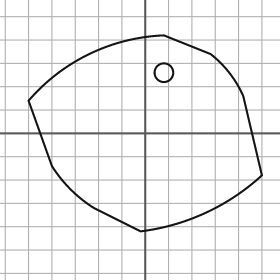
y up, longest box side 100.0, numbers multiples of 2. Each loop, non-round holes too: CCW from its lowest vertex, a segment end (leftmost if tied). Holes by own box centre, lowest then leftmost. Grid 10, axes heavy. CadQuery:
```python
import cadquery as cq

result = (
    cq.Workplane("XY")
    .moveTo(-2.0, -42.0)
    .threePointArc((26.0, -34.0), (50.0, -18.0))
    .lineTo(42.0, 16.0)
    .threePointArc((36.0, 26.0), (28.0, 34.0))
    .lineTo(8.0, 42.0)
    .threePointArc((-24.0, 34.0), (-50.0, 14.0))
    .lineTo(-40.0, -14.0)
    .threePointArc((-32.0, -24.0), (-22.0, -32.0))
    .close()
    .moveTo(8.0, 26.0)
    .circle(4.0)
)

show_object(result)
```